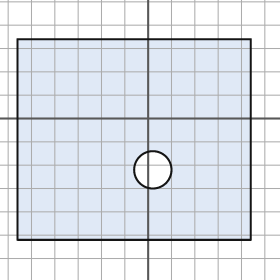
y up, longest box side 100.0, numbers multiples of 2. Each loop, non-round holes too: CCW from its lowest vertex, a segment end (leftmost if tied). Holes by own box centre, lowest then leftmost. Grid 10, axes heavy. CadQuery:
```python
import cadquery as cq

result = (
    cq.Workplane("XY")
    .moveTo(-56.0, -52.0)
    .lineTo(44.0, -52.0)
    .lineTo(44.0, 34.0)
    .lineTo(-56.0, 34.0)
    .close()
    .moveTo(2.0, -22.0)
    .circle(8.0)
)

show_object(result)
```